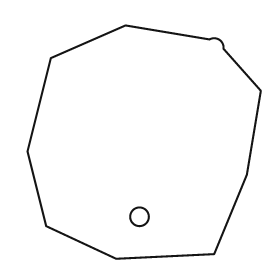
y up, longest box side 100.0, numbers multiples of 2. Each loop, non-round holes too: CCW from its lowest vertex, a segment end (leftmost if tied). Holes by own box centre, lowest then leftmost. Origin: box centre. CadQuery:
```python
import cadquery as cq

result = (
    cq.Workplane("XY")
    .moveTo(-12.0, -50.0)
    .lineTo(30.0, -48.0)
    .lineTo(44.0, -14.0)
    .lineTo(50.0, 22.0)
    .lineTo(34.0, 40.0)
    .threePointArc((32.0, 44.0), (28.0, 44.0))
    .lineTo(-8.0, 50.0)
    .lineTo(-40.0, 36.0)
    .lineTo(-50.0, -4.0)
    .lineTo(-42.0, -36.0)
    .close()
    .moveTo(-2.0, -32.0)
    .circle(4.0)
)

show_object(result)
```